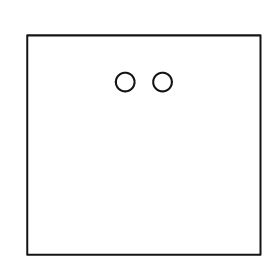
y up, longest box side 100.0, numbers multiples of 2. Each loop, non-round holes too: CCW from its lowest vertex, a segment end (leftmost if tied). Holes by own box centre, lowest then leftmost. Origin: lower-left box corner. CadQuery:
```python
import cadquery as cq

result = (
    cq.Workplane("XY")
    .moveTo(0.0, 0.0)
    .lineTo(100.0, 0.0)
    .lineTo(100.0, 94.0)
    .lineTo(0.0, 94.0)
    .close()
    .moveTo(42.0, 74.0)
    .circle(4.0)
    .moveTo(58.0, 74.0)
    .circle(4.0)
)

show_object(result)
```